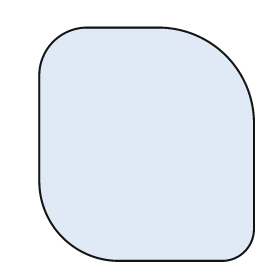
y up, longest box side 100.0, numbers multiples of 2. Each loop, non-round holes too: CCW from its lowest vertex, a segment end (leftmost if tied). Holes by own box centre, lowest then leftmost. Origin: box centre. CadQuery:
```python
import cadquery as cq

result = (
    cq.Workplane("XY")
    .moveTo(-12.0, -50.0)
    .lineTo(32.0, -50.0)
    .threePointArc((42.0, -46.0), (46.0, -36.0))
    .lineTo(46.0, 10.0)
    .threePointArc((34.0, 38.0), (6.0, 50.0))
    .lineTo(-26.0, 50.0)
    .threePointArc((-40.0, 44.0), (-46.0, 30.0))
    .lineTo(-46.0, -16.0)
    .threePointArc((-36.0, -40.0), (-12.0, -50.0))
    .close()
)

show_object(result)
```